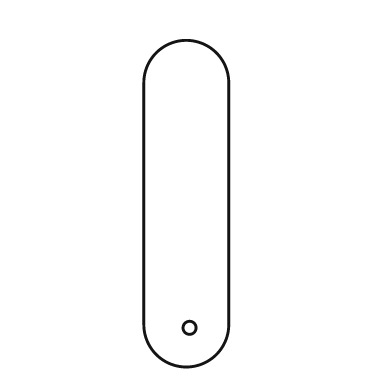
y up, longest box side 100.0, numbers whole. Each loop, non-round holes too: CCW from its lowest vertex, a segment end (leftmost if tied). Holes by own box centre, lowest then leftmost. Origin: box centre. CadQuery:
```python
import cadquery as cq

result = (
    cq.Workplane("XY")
    .moveTo(-13.0, -37.0)
    .threePointArc((0.0, -50.0), (13.0, -37.0))
    .lineTo(13.0, 37.0)
    .threePointArc((0.0, 50.0), (-13.0, 37.0))
    .close()
    .moveTo(1.0, -38.0)
    .circle(2.0)
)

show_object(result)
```